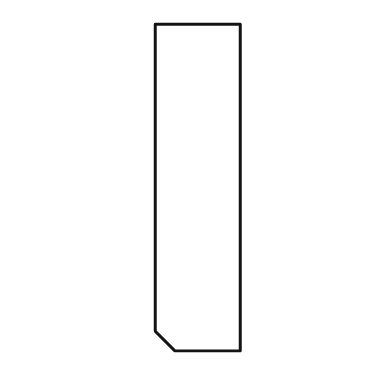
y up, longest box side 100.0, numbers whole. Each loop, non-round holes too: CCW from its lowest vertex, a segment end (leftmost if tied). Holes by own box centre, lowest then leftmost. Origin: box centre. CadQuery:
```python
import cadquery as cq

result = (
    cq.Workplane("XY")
    .moveTo(-7.0, -50.0)
    .lineTo(13.0, -50.0)
    .lineTo(13.0, 50.0)
    .lineTo(-13.0, 50.0)
    .lineTo(-13.0, -44.0)
    .close()
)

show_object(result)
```